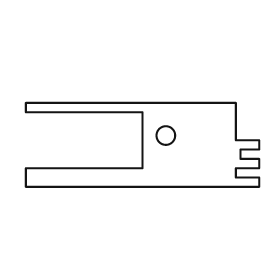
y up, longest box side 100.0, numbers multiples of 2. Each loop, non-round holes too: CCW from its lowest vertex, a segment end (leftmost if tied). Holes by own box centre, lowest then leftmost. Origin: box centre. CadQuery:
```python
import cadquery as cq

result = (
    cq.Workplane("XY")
    .moveTo(-50.0, -18.0)
    .lineTo(50.0, -18.0)
    .lineTo(50.0, -14.0)
    .lineTo(40.0, -14.0)
    .lineTo(40.0, -10.0)
    .lineTo(50.0, -10.0)
    .lineTo(50.0, -6.0)
    .lineTo(42.0, -6.0)
    .lineTo(42.0, -2.0)
    .lineTo(50.0, -2.0)
    .lineTo(50.0, 2.0)
    .lineTo(40.0, 2.0)
    .lineTo(40.0, 18.0)
    .lineTo(-50.0, 18.0)
    .lineTo(-50.0, 14.0)
    .lineTo(0.0, 14.0)
    .lineTo(0.0, -10.0)
    .lineTo(-50.0, -10.0)
    .close()
    .moveTo(10.0, 4.0)
    .circle(4.0)
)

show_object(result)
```